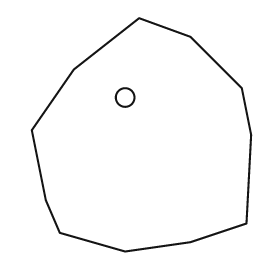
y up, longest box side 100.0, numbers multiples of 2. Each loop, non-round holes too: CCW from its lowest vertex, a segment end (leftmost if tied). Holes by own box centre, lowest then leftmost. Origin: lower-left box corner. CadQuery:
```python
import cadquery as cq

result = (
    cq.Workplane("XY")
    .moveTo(40.0, 0.0)
    .lineTo(68.0, 4.0)
    .lineTo(92.0, 12.0)
    .lineTo(94.0, 50.0)
    .lineTo(90.0, 70.0)
    .lineTo(68.0, 92.0)
    .lineTo(46.0, 100.0)
    .lineTo(18.0, 78.0)
    .lineTo(0.0, 52.0)
    .lineTo(6.0, 22.0)
    .lineTo(12.0, 8.0)
    .close()
    .moveTo(40.0, 66.0)
    .circle(4.0)
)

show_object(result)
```